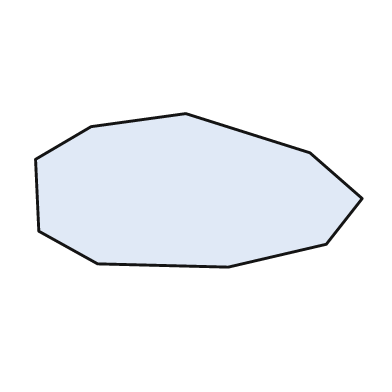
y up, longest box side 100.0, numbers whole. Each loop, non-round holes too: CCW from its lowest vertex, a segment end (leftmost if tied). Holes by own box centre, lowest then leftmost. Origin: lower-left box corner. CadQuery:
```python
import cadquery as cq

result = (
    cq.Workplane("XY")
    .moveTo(59.0, 0.0)
    .lineTo(89.0, 7.0)
    .lineTo(100.0, 21.0)
    .lineTo(84.0, 35.0)
    .lineTo(46.0, 47.0)
    .lineTo(17.0, 43.0)
    .lineTo(0.0, 33.0)
    .lineTo(1.0, 11.0)
    .lineTo(19.0, 1.0)
    .close()
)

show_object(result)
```